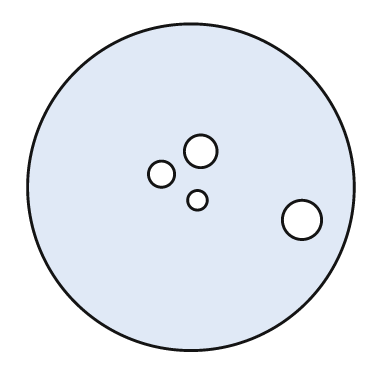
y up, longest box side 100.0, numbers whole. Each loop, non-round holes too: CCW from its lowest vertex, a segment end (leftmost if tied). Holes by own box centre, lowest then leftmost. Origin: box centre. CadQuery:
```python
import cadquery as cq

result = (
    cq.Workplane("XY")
    .moveTo(0.0, 0.0)
    .circle(50.0)
    .moveTo(34.0, -10.0)
    .circle(6.0)
    .moveTo(2.0, -4.0)
    .circle(3.0)
    .moveTo(-9.0, 4.0)
    .circle(4.0)
    .moveTo(3.0, 11.0)
    .circle(5.0)
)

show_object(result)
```